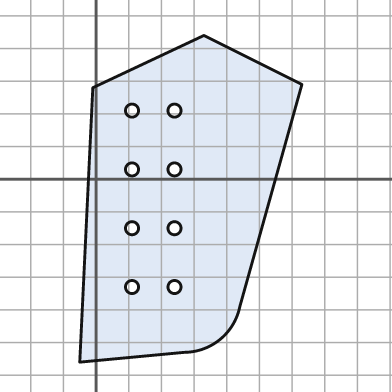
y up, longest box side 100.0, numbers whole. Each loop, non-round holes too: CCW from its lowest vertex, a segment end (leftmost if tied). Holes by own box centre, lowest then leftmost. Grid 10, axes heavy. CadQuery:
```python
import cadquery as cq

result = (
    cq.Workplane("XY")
    .moveTo(-5.0, -56.0)
    .lineTo(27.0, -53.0)
    .threePointArc((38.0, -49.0), (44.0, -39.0))
    .lineTo(63.0, 29.0)
    .lineTo(33.0, 44.0)
    .lineTo(-1.0, 28.0)
    .close()
    .moveTo(11.0, -33.0)
    .circle(2.0)
    .moveTo(24.0, -33.0)
    .circle(2.0)
    .moveTo(11.0, -15.0)
    .circle(2.0)
    .moveTo(24.0, -15.0)
    .circle(2.0)
    .moveTo(11.0, 3.0)
    .circle(2.0)
    .moveTo(24.0, 3.0)
    .circle(2.0)
    .moveTo(11.0, 21.0)
    .circle(2.0)
    .moveTo(24.0, 21.0)
    .circle(2.0)
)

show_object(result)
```